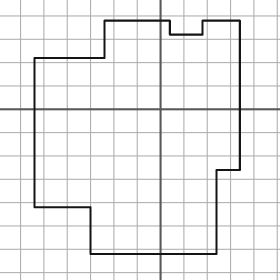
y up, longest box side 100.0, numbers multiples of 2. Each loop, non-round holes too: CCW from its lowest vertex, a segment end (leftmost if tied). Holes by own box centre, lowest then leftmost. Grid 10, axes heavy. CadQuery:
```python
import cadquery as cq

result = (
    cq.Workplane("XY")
    .moveTo(-30.0, -62.0)
    .lineTo(24.0, -62.0)
    .lineTo(24.0, -26.0)
    .lineTo(34.0, -26.0)
    .lineTo(34.0, 38.0)
    .lineTo(18.0, 38.0)
    .lineTo(18.0, 32.0)
    .lineTo(4.0, 32.0)
    .lineTo(4.0, 38.0)
    .lineTo(-24.0, 38.0)
    .lineTo(-24.0, 22.0)
    .lineTo(-54.0, 22.0)
    .lineTo(-54.0, -42.0)
    .lineTo(-30.0, -42.0)
    .close()
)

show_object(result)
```